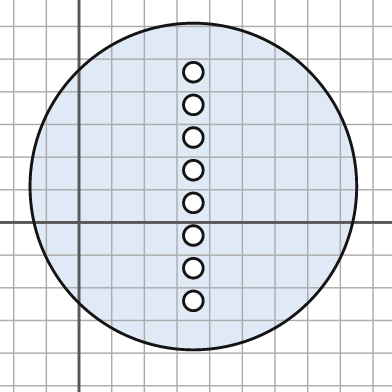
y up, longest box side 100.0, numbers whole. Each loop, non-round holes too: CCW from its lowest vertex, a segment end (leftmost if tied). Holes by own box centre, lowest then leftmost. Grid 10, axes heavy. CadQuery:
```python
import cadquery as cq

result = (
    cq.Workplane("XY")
    .moveTo(35.0, 11.0)
    .circle(50.0)
    .moveTo(35.0, -24.0)
    .circle(3.0)
    .moveTo(35.0, -14.0)
    .circle(3.0)
    .moveTo(35.0, -4.0)
    .circle(3.0)
    .moveTo(35.0, 6.0)
    .circle(3.0)
    .moveTo(35.0, 16.0)
    .circle(3.0)
    .moveTo(35.0, 26.0)
    .circle(3.0)
    .moveTo(35.0, 36.0)
    .circle(3.0)
    .moveTo(35.0, 46.0)
    .circle(3.0)
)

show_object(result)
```